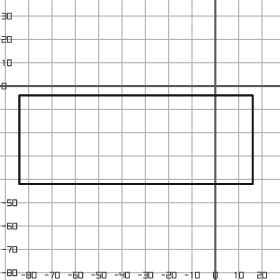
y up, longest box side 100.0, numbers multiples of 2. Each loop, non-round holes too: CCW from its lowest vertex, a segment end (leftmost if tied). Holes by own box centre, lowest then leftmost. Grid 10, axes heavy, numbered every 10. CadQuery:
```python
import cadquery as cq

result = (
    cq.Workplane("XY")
    .moveTo(-84.0, -42.0)
    .lineTo(16.0, -42.0)
    .lineTo(16.0, -4.0)
    .lineTo(-84.0, -4.0)
    .close()
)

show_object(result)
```